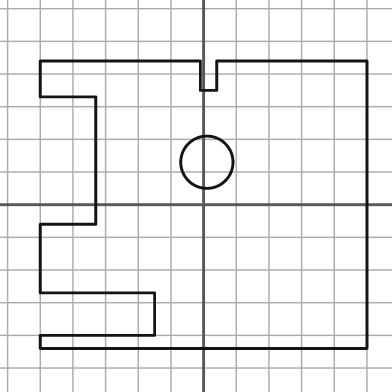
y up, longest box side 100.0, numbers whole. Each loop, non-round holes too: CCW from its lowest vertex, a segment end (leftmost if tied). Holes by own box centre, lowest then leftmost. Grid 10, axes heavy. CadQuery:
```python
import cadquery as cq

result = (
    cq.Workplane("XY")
    .moveTo(-50.0, -44.0)
    .lineTo(50.0, -44.0)
    .lineTo(50.0, 44.0)
    .lineTo(4.0, 44.0)
    .lineTo(4.0, 35.0)
    .lineTo(-1.0, 35.0)
    .lineTo(-1.0, 44.0)
    .lineTo(-50.0, 44.0)
    .lineTo(-50.0, 33.0)
    .lineTo(-33.0, 33.0)
    .lineTo(-33.0, -6.0)
    .lineTo(-50.0, -6.0)
    .lineTo(-50.0, -27.0)
    .lineTo(-15.0, -27.0)
    .lineTo(-15.0, -40.0)
    .lineTo(-50.0, -40.0)
    .close()
    .moveTo(1.0, 13.0)
    .circle(8.0)
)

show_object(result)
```